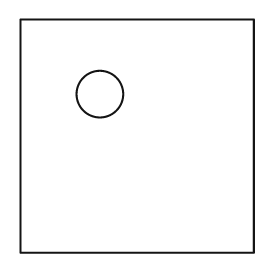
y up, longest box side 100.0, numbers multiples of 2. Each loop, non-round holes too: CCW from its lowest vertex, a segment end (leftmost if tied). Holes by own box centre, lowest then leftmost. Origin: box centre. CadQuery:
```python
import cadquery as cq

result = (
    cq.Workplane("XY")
    .moveTo(-50.0, -50.0)
    .lineTo(50.0, -50.0)
    .lineTo(50.0, 50.0)
    .lineTo(-50.0, 50.0)
    .close()
    .moveTo(-16.0, 18.0)
    .circle(10.0)
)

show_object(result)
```